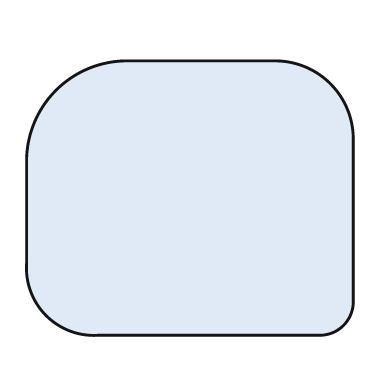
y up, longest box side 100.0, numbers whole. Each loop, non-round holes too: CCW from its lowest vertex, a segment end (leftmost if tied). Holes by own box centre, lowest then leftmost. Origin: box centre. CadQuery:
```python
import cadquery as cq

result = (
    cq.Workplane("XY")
    .moveTo(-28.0, -42.0)
    .lineTo(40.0, -42.0)
    .threePointArc((47.0, -39.0), (50.0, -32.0))
    .lineTo(50.0, 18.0)
    .threePointArc((43.0, 35.0), (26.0, 42.0))
    .lineTo(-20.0, 42.0)
    .threePointArc((-41.0, 33.0), (-50.0, 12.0))
    .lineTo(-50.0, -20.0)
    .threePointArc((-44.0, -36.0), (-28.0, -42.0))
    .close()
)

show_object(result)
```